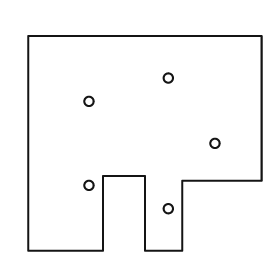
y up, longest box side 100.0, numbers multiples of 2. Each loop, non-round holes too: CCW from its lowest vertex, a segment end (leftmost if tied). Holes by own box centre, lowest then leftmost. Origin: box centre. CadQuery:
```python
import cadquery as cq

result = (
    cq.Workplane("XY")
    .moveTo(-50.0, -46.0)
    .lineTo(-18.0, -46.0)
    .lineTo(-18.0, -14.0)
    .lineTo(0.0, -14.0)
    .lineTo(0.0, -46.0)
    .lineTo(16.0, -46.0)
    .lineTo(16.0, -16.0)
    .lineTo(50.0, -16.0)
    .lineTo(50.0, 46.0)
    .lineTo(-50.0, 46.0)
    .close()
    .moveTo(10.0, -28.0)
    .circle(2.0)
    .moveTo(-24.0, -18.0)
    .circle(2.0)
    .moveTo(30.0, 0.0)
    .circle(2.0)
    .moveTo(-24.0, 18.0)
    .circle(2.0)
    .moveTo(10.0, 28.0)
    .circle(2.0)
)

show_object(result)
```